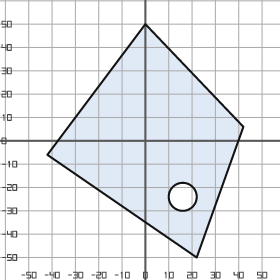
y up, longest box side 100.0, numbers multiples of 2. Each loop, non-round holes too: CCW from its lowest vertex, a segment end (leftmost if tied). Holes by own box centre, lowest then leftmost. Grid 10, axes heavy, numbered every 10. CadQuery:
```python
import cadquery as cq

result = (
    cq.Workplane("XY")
    .moveTo(22.0, -50.0)
    .lineTo(42.0, 6.0)
    .lineTo(0.0, 50.0)
    .lineTo(-42.0, -6.0)
    .close()
    .moveTo(16.0, -24.0)
    .circle(6.0)
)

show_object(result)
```